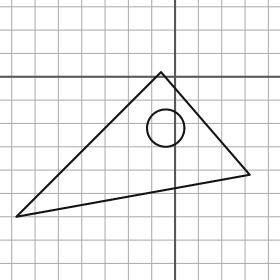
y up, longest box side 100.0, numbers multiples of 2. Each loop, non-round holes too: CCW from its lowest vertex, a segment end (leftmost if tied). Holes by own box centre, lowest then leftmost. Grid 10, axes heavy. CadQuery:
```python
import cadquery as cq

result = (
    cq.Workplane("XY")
    .moveTo(-68.0, -60.0)
    .lineTo(32.0, -42.0)
    .lineTo(-6.0, 2.0)
    .close()
    .moveTo(-4.0, -22.0)
    .circle(8.0)
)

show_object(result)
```